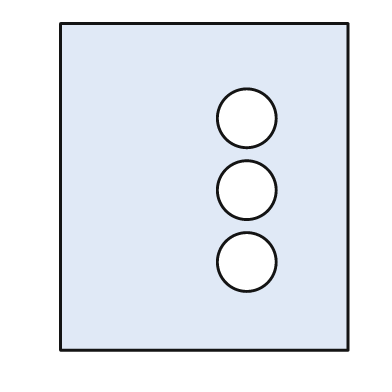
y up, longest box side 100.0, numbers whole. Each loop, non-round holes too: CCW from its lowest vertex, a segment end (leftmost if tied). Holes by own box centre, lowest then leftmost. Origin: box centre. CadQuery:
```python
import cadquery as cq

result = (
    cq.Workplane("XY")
    .moveTo(-44.0, -50.0)
    .lineTo(44.0, -50.0)
    .lineTo(44.0, 50.0)
    .lineTo(-44.0, 50.0)
    .close()
    .moveTo(13.0, -23.0)
    .circle(9.0)
    .moveTo(13.0, -1.0)
    .circle(9.0)
    .moveTo(13.0, 21.0)
    .circle(9.0)
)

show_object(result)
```